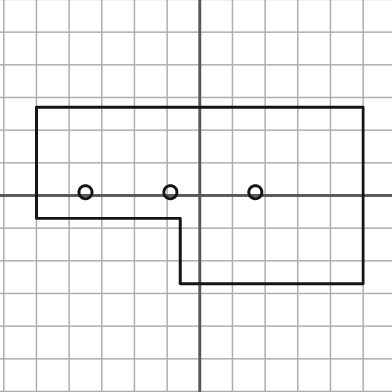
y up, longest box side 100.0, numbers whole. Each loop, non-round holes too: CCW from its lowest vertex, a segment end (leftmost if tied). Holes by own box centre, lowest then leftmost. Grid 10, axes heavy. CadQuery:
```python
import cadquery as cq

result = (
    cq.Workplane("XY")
    .moveTo(-6.0, -27.0)
    .lineTo(50.0, -27.0)
    .lineTo(50.0, 27.0)
    .lineTo(-50.0, 27.0)
    .lineTo(-50.0, -7.0)
    .lineTo(-6.0, -7.0)
    .close()
    .moveTo(-35.0, 1.0)
    .circle(2.0)
    .moveTo(-9.0, 1.0)
    .circle(2.0)
    .moveTo(17.0, 1.0)
    .circle(2.0)
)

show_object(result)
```